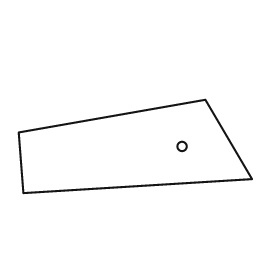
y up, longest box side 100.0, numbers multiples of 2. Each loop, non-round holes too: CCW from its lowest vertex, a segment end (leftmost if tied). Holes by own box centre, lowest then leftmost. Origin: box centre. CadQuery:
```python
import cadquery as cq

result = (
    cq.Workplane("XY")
    .moveTo(-48.0, -20.0)
    .lineTo(50.0, -14.0)
    .lineTo(30.0, 20.0)
    .lineTo(-50.0, 6.0)
    .close()
    .moveTo(20.0, 0.0)
    .circle(2.0)
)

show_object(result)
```